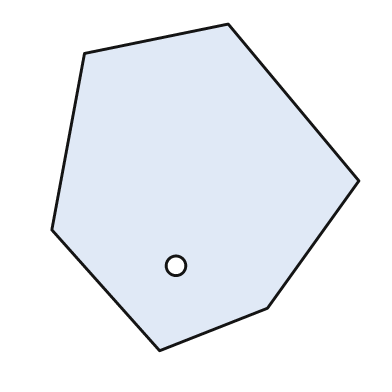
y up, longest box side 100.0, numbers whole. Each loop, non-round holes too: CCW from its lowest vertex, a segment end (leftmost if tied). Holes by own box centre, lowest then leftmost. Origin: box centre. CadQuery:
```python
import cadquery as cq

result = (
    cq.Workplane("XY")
    .moveTo(-14.0, -50.0)
    .lineTo(19.0, -37.0)
    .lineTo(47.0, 2.0)
    .lineTo(7.0, 50.0)
    .lineTo(-37.0, 41.0)
    .lineTo(-47.0, -13.0)
    .close()
    .moveTo(-9.0, -24.0)
    .circle(3.0)
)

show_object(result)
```